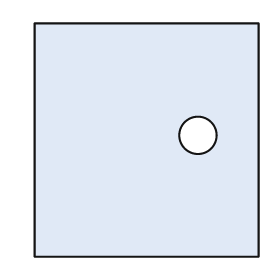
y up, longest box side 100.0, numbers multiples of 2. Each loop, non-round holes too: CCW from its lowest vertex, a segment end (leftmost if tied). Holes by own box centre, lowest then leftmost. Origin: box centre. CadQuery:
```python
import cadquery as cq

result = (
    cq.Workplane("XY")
    .moveTo(-48.0, -50.0)
    .lineTo(48.0, -50.0)
    .lineTo(48.0, 50.0)
    .lineTo(-48.0, 50.0)
    .close()
    .moveTo(22.0, 2.0)
    .circle(8.0)
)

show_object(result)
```